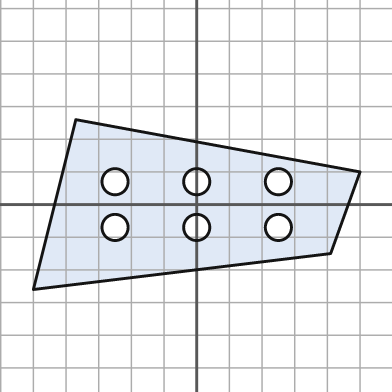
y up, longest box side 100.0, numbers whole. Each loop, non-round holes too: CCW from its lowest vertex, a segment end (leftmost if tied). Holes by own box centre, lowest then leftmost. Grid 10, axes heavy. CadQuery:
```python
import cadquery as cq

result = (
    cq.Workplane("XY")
    .moveTo(-50.0, -26.0)
    .lineTo(41.0, -15.0)
    .lineTo(50.0, 10.0)
    .lineTo(-37.0, 26.0)
    .close()
    .moveTo(-25.0, -7.0)
    .circle(4.0)
    .moveTo(0.0, -7.0)
    .circle(4.0)
    .moveTo(25.0, -7.0)
    .circle(4.0)
    .moveTo(-25.0, 7.0)
    .circle(4.0)
    .moveTo(0.0, 7.0)
    .circle(4.0)
    .moveTo(25.0, 7.0)
    .circle(4.0)
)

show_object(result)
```